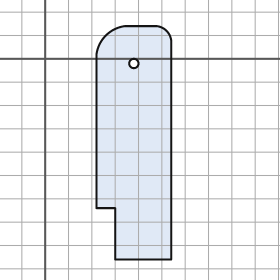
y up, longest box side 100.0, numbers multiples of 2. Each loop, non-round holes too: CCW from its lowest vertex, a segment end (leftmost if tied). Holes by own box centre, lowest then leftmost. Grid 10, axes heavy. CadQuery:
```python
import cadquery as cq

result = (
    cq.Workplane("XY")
    .moveTo(30.0, -86.0)
    .lineTo(54.0, -86.0)
    .lineTo(54.0, 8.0)
    .threePointArc((52.0, 12.0), (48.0, 14.0))
    .lineTo(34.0, 14.0)
    .threePointArc((26.0, 10.0), (22.0, 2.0))
    .lineTo(22.0, -64.0)
    .lineTo(30.0, -64.0)
    .close()
    .moveTo(38.0, -2.0)
    .circle(2.0)
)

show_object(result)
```